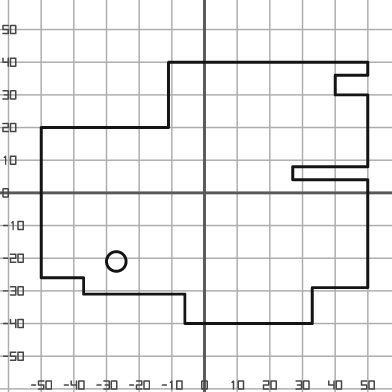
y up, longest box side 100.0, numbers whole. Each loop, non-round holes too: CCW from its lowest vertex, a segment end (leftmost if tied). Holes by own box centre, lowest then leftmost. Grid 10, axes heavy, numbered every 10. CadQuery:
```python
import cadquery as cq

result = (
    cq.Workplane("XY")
    .moveTo(-6.0, -40.0)
    .lineTo(33.0, -40.0)
    .lineTo(33.0, -29.0)
    .lineTo(50.0, -29.0)
    .lineTo(50.0, 4.0)
    .lineTo(27.0, 4.0)
    .lineTo(27.0, 8.0)
    .lineTo(50.0, 8.0)
    .lineTo(50.0, 30.0)
    .lineTo(40.0, 30.0)
    .lineTo(40.0, 36.0)
    .lineTo(50.0, 36.0)
    .lineTo(50.0, 40.0)
    .lineTo(-11.0, 40.0)
    .lineTo(-11.0, 20.0)
    .lineTo(-50.0, 20.0)
    .lineTo(-50.0, -26.0)
    .lineTo(-37.0, -26.0)
    .lineTo(-37.0, -31.0)
    .lineTo(-6.0, -31.0)
    .close()
    .moveTo(-27.0, -21.0)
    .circle(3.0)
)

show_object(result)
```